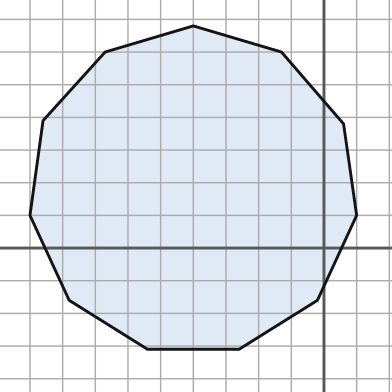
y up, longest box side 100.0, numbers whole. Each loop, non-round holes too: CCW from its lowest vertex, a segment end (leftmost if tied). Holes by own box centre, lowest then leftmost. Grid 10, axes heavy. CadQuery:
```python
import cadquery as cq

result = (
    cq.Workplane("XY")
    .moveTo(-54.0, -31.0)
    .lineTo(-26.0, -31.0)
    .lineTo(-2.0, -16.0)
    .lineTo(10.0, 10.0)
    .lineTo(6.0, 38.0)
    .lineTo(-13.0, 60.0)
    .lineTo(-40.0, 68.0)
    .lineTo(-67.0, 60.0)
    .lineTo(-86.0, 39.0)
    .lineTo(-90.0, 10.0)
    .lineTo(-78.0, -16.0)
    .close()
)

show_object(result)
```